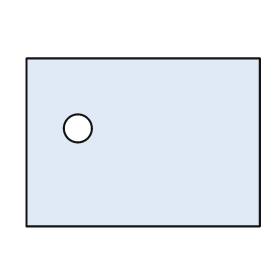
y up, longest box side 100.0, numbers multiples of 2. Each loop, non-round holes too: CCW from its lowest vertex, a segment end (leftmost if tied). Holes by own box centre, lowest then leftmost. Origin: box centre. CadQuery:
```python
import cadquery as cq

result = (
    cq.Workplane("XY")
    .moveTo(-50.0, -36.0)
    .lineTo(50.0, -36.0)
    .lineTo(50.0, 36.0)
    .lineTo(-50.0, 36.0)
    .close()
    .moveTo(-28.0, 6.0)
    .circle(6.0)
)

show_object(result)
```